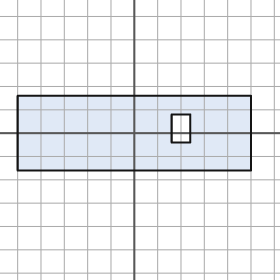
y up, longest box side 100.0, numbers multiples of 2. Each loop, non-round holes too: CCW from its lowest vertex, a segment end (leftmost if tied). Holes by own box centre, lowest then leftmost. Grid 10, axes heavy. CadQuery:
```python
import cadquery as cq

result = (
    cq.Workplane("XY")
    .moveTo(-50.0, -16.0)
    .lineTo(50.0, -16.0)
    .lineTo(50.0, 16.0)
    .lineTo(-50.0, 16.0)
    .close()
    .moveTo(16.0, -4.0)
    .lineTo(24.0, -4.0)
    .lineTo(24.0, 8.0)
    .lineTo(16.0, 8.0)
    .close()
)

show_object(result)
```